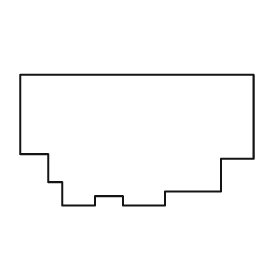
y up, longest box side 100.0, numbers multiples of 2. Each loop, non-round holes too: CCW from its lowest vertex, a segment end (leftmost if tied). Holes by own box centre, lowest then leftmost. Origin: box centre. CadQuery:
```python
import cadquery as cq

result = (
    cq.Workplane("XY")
    .moveTo(-32.0, -28.0)
    .lineTo(-18.0, -28.0)
    .lineTo(-18.0, -24.0)
    .lineTo(-6.0, -24.0)
    .lineTo(-6.0, -28.0)
    .lineTo(12.0, -28.0)
    .lineTo(12.0, -22.0)
    .lineTo(36.0, -22.0)
    .lineTo(36.0, -8.0)
    .lineTo(50.0, -8.0)
    .lineTo(50.0, 28.0)
    .lineTo(-50.0, 28.0)
    .lineTo(-50.0, -6.0)
    .lineTo(-38.0, -6.0)
    .lineTo(-38.0, -18.0)
    .lineTo(-32.0, -18.0)
    .close()
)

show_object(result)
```